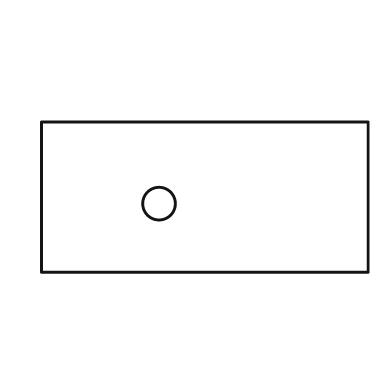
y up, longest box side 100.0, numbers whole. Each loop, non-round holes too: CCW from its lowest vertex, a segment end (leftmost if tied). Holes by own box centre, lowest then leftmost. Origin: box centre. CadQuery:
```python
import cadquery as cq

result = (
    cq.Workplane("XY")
    .moveTo(-50.0, -23.0)
    .lineTo(50.0, -23.0)
    .lineTo(50.0, 23.0)
    .lineTo(-50.0, 23.0)
    .close()
    .moveTo(-14.0, -2.0)
    .circle(5.0)
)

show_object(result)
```